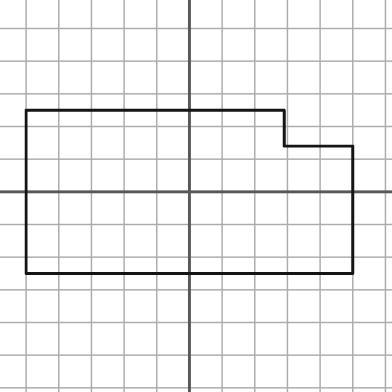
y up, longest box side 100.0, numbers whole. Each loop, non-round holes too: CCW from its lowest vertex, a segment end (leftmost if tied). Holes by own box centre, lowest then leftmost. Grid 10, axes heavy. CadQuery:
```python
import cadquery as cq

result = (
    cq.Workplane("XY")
    .moveTo(-50.0, -25.0)
    .lineTo(50.0, -25.0)
    .lineTo(50.0, 14.0)
    .lineTo(29.0, 14.0)
    .lineTo(29.0, 25.0)
    .lineTo(-50.0, 25.0)
    .close()
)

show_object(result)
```